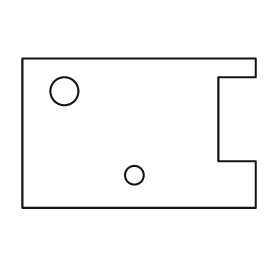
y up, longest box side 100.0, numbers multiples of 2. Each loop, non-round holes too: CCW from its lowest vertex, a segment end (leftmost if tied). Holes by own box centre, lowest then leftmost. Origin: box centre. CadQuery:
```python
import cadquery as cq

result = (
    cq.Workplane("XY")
    .moveTo(-50.0, -32.0)
    .lineTo(50.0, -32.0)
    .lineTo(50.0, -12.0)
    .lineTo(34.0, -12.0)
    .lineTo(34.0, 24.0)
    .lineTo(50.0, 24.0)
    .lineTo(50.0, 32.0)
    .lineTo(-50.0, 32.0)
    .close()
    .moveTo(-2.0, -18.0)
    .circle(4.0)
    .moveTo(-32.0, 18.0)
    .circle(6.0)
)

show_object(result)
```